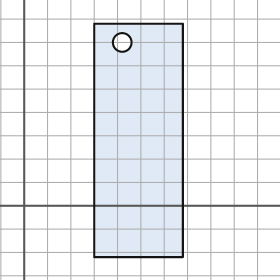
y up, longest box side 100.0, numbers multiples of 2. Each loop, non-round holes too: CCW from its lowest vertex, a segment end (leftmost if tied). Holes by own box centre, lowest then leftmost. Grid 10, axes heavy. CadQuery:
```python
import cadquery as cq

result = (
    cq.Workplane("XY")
    .moveTo(30.0, -22.0)
    .lineTo(68.0, -22.0)
    .lineTo(68.0, 78.0)
    .lineTo(30.0, 78.0)
    .close()
    .moveTo(42.0, 70.0)
    .circle(4.0)
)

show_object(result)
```